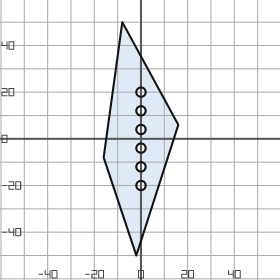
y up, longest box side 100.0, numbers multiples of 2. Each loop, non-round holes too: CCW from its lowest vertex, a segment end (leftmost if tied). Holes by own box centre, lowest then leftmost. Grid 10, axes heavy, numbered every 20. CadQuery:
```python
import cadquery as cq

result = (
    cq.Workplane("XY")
    .moveTo(-2.0, -50.0)
    .lineTo(16.0, 6.0)
    .lineTo(-8.0, 50.0)
    .lineTo(-16.0, -8.0)
    .close()
    .moveTo(0.0, -20.0)
    .circle(2.0)
    .moveTo(0.0, -12.0)
    .circle(2.0)
    .moveTo(0.0, -4.0)
    .circle(2.0)
    .moveTo(0.0, 4.0)
    .circle(2.0)
    .moveTo(0.0, 12.0)
    .circle(2.0)
    .moveTo(0.0, 20.0)
    .circle(2.0)
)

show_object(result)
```